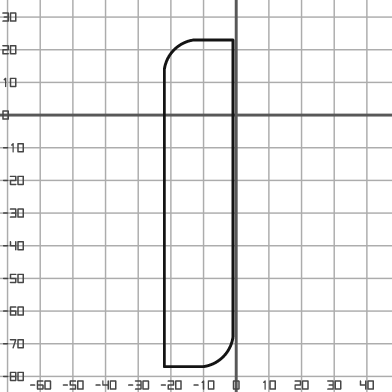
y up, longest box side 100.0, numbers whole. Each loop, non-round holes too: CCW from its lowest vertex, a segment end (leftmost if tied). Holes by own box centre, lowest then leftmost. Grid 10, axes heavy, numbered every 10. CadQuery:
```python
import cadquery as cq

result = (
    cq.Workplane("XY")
    .moveTo(-22.0, -77.0)
    .lineTo(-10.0, -77.0)
    .threePointArc((-4.0, -74.0), (-1.0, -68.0))
    .lineTo(-1.0, 23.0)
    .lineTo(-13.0, 23.0)
    .threePointArc((-19.0, 20.0), (-22.0, 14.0))
    .close()
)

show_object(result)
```